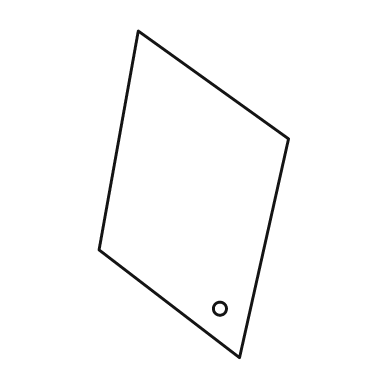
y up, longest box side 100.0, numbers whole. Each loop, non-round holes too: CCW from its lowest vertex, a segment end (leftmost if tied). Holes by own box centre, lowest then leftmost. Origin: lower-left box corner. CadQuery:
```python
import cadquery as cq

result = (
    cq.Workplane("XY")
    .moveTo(43.0, 0.0)
    .lineTo(58.0, 67.0)
    .lineTo(12.0, 100.0)
    .lineTo(0.0, 33.0)
    .close()
    .moveTo(37.0, 15.0)
    .circle(2.0)
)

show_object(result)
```